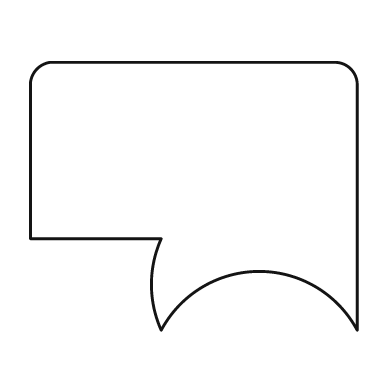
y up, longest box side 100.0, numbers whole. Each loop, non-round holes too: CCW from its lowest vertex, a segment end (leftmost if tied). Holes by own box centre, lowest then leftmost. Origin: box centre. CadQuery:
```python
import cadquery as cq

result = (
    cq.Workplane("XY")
    .moveTo(-10.0, -41.0)
    .threePointArc((20.0, -23.0), (50.0, -41.0))
    .lineTo(50.0, 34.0)
    .threePointArc((48.0, 39.0), (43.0, 41.0))
    .lineTo(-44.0, 41.0)
    .threePointArc((-48.0, 39.0), (-50.0, 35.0))
    .lineTo(-50.0, -13.0)
    .lineTo(-10.0, -13.0)
    .threePointArc((-13.0, -27.0), (-10.0, -41.0))
    .close()
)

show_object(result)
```